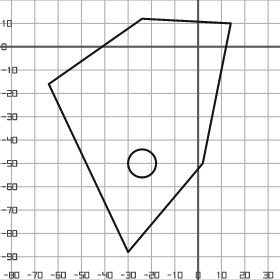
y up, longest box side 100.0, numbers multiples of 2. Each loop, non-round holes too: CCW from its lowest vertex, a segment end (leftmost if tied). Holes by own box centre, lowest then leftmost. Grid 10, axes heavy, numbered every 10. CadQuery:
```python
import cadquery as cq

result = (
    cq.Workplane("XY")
    .moveTo(-30.0, -88.0)
    .lineTo(2.0, -50.0)
    .lineTo(14.0, 10.0)
    .lineTo(-24.0, 12.0)
    .lineTo(-64.0, -16.0)
    .close()
    .moveTo(-24.0, -50.0)
    .circle(6.0)
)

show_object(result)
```